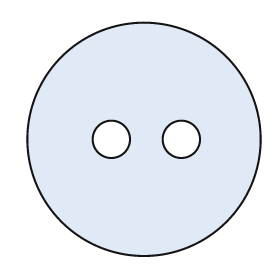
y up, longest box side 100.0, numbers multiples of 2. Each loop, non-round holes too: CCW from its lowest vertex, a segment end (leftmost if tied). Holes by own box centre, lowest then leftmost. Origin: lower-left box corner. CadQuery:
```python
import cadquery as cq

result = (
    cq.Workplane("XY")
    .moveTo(50.0, 50.0)
    .circle(50.0)
    .moveTo(36.0, 50.0)
    .circle(8.0)
    .moveTo(66.0, 50.0)
    .circle(8.0)
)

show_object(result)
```